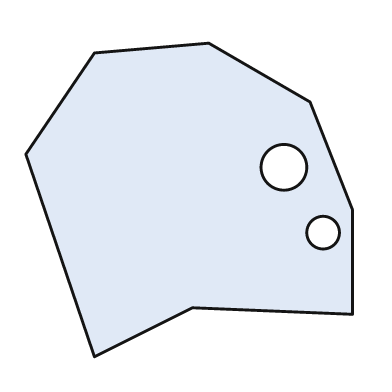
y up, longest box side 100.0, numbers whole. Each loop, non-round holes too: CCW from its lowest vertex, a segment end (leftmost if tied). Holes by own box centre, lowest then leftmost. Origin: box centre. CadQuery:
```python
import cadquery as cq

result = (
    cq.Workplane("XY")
    .moveTo(-29.0, -48.0)
    .lineTo(1.0, -33.0)
    .lineTo(50.0, -35.0)
    .lineTo(50.0, -3.0)
    .lineTo(37.0, 30.0)
    .lineTo(6.0, 48.0)
    .lineTo(-29.0, 45.0)
    .lineTo(-50.0, 14.0)
    .close()
    .moveTo(41.0, -10.0)
    .circle(5.0)
    .moveTo(29.0, 10.0)
    .circle(7.0)
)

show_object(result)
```